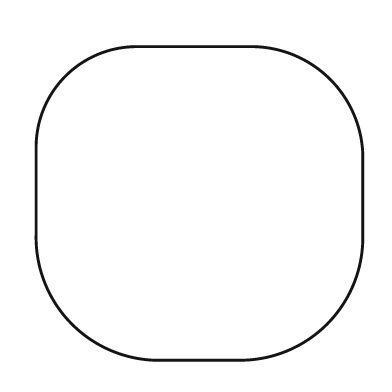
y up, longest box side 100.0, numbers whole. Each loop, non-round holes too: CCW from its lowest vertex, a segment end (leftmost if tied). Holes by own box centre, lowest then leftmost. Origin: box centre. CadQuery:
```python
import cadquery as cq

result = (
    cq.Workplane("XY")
    .moveTo(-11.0, -48.0)
    .lineTo(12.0, -48.0)
    .threePointArc((39.0, -37.0), (50.0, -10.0))
    .lineTo(50.0, 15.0)
    .threePointArc((40.0, 38.0), (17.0, 48.0))
    .lineTo(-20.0, 48.0)
    .threePointArc((-41.0, 39.0), (-50.0, 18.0))
    .lineTo(-50.0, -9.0)
    .threePointArc((-39.0, -37.0), (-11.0, -48.0))
    .close()
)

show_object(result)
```